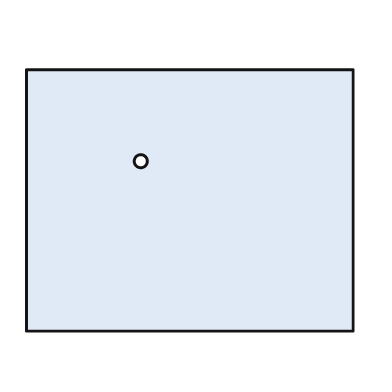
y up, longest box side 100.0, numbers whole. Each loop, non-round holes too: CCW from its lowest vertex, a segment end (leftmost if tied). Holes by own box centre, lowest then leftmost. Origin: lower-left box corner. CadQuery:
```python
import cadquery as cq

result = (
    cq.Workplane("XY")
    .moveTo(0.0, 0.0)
    .lineTo(100.0, 0.0)
    .lineTo(100.0, 80.0)
    .lineTo(0.0, 80.0)
    .close()
    .moveTo(35.0, 52.0)
    .circle(2.0)
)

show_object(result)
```